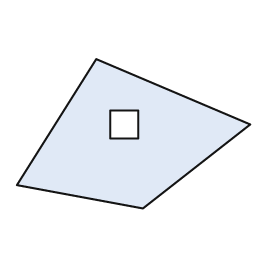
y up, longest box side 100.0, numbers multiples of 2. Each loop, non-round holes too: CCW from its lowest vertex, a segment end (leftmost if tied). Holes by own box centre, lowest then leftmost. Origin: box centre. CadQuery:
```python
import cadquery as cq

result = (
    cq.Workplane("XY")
    .moveTo(4.0, -32.0)
    .lineTo(50.0, 4.0)
    .lineTo(-16.0, 32.0)
    .lineTo(-50.0, -22.0)
    .close()
    .moveTo(-10.0, -2.0)
    .lineTo(2.0, -2.0)
    .lineTo(2.0, 10.0)
    .lineTo(-10.0, 10.0)
    .close()
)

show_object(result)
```